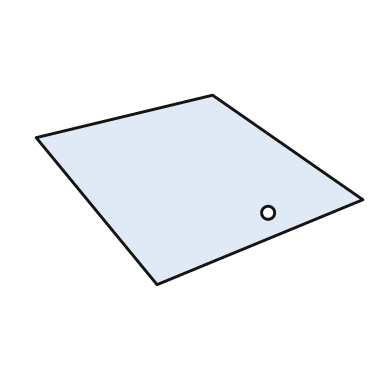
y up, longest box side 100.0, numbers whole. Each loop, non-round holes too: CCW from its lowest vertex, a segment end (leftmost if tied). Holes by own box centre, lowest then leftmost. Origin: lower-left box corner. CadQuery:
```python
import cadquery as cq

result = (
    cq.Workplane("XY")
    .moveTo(37.0, 0.0)
    .lineTo(100.0, 26.0)
    .lineTo(54.0, 58.0)
    .lineTo(0.0, 45.0)
    .close()
    .moveTo(71.0, 22.0)
    .circle(2.0)
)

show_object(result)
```